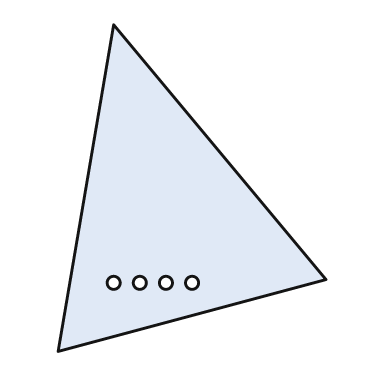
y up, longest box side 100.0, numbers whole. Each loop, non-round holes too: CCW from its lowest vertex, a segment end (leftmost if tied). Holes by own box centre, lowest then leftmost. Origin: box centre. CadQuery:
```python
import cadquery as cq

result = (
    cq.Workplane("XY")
    .moveTo(-41.0, -50.0)
    .lineTo(41.0, -28.0)
    .lineTo(-24.0, 50.0)
    .close()
    .moveTo(-24.0, -29.0)
    .circle(2.0)
    .moveTo(-16.0, -29.0)
    .circle(2.0)
    .moveTo(-8.0, -29.0)
    .circle(2.0)
    .moveTo(0.0, -29.0)
    .circle(2.0)
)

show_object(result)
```